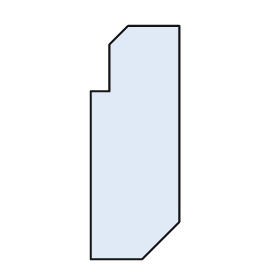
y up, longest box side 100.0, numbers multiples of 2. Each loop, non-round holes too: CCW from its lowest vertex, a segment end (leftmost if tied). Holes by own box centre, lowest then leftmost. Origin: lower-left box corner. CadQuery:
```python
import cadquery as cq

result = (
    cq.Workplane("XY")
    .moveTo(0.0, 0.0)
    .lineTo(22.0, 0.0)
    .lineTo(38.0, 16.0)
    .lineTo(38.0, 100.0)
    .lineTo(16.0, 100.0)
    .lineTo(8.0, 92.0)
    .lineTo(8.0, 72.0)
    .lineTo(0.0, 72.0)
    .close()
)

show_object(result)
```